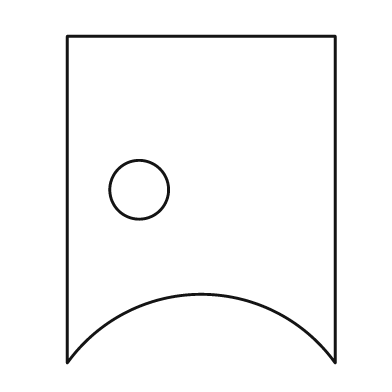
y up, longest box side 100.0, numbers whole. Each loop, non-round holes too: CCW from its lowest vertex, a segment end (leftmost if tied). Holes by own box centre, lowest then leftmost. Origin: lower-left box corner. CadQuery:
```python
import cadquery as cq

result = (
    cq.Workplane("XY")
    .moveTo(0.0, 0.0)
    .threePointArc((41.0, 21.0), (82.0, 0.0))
    .lineTo(82.0, 100.0)
    .lineTo(0.0, 100.0)
    .close()
    .moveTo(22.0, 53.0)
    .circle(9.0)
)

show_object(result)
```